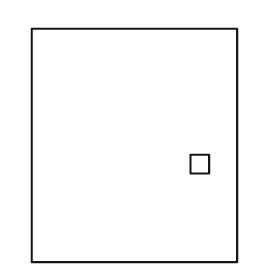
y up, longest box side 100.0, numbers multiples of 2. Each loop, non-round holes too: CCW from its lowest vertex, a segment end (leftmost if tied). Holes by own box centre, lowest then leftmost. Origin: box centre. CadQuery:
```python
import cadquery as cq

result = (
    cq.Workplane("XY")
    .moveTo(-44.0, -50.0)
    .lineTo(44.0, -50.0)
    .lineTo(44.0, 50.0)
    .lineTo(-44.0, 50.0)
    .close()
    .moveTo(24.0, -12.0)
    .lineTo(32.0, -12.0)
    .lineTo(32.0, -4.0)
    .lineTo(24.0, -4.0)
    .close()
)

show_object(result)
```